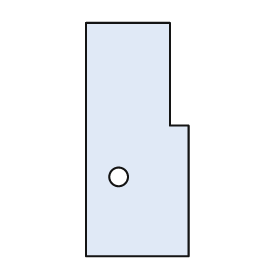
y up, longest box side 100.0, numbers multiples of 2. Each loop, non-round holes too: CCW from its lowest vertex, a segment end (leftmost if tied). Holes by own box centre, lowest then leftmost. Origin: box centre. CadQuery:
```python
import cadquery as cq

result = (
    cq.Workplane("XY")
    .moveTo(-22.0, -50.0)
    .lineTo(22.0, -50.0)
    .lineTo(22.0, 6.0)
    .lineTo(14.0, 6.0)
    .lineTo(14.0, 50.0)
    .lineTo(-22.0, 50.0)
    .close()
    .moveTo(-8.0, -16.0)
    .circle(4.0)
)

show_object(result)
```